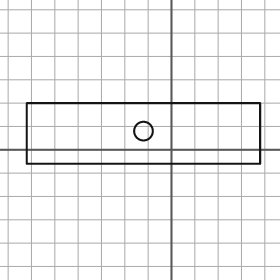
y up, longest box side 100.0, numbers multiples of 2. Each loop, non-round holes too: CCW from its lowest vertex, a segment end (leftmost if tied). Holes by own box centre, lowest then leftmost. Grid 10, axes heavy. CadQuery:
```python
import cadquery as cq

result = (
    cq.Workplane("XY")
    .moveTo(-62.0, -6.0)
    .lineTo(38.0, -6.0)
    .lineTo(38.0, 20.0)
    .lineTo(-62.0, 20.0)
    .close()
    .moveTo(-12.0, 8.0)
    .circle(4.0)
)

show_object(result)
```